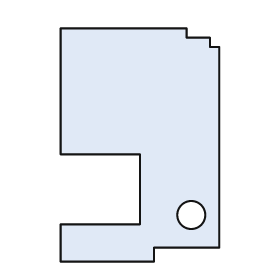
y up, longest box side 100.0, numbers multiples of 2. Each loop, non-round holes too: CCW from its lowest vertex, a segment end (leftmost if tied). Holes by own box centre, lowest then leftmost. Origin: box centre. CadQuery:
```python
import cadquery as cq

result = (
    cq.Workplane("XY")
    .moveTo(-34.0, -50.0)
    .lineTo(6.0, -50.0)
    .lineTo(6.0, -44.0)
    .lineTo(34.0, -44.0)
    .lineTo(34.0, 42.0)
    .lineTo(30.0, 42.0)
    .lineTo(30.0, 46.0)
    .lineTo(20.0, 46.0)
    .lineTo(20.0, 50.0)
    .lineTo(-34.0, 50.0)
    .lineTo(-34.0, -4.0)
    .lineTo(0.0, -4.0)
    .lineTo(0.0, -34.0)
    .lineTo(-34.0, -34.0)
    .close()
    .moveTo(22.0, -30.0)
    .circle(6.0)
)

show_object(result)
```